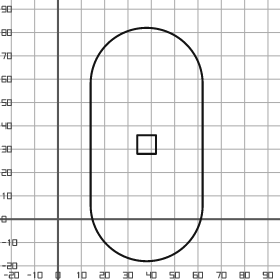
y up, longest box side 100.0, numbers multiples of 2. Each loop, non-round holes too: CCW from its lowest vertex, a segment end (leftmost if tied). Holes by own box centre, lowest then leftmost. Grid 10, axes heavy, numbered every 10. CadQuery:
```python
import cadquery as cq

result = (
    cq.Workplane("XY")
    .moveTo(14.0, 6.0)
    .threePointArc((38.0, -18.0), (62.0, 6.0))
    .lineTo(62.0, 58.0)
    .threePointArc((38.0, 82.0), (14.0, 58.0))
    .close()
    .moveTo(34.0, 28.0)
    .lineTo(42.0, 28.0)
    .lineTo(42.0, 36.0)
    .lineTo(34.0, 36.0)
    .close()
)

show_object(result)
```